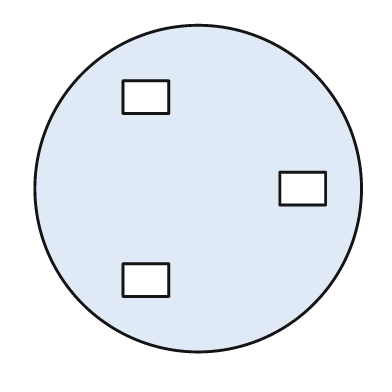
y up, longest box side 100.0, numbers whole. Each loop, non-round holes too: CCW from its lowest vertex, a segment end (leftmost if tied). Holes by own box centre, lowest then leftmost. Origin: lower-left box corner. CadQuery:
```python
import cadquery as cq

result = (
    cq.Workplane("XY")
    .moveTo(50.0, 50.0)
    .circle(50.0)
    .moveTo(27.0, 17.0)
    .lineTo(41.0, 17.0)
    .lineTo(41.0, 27.0)
    .lineTo(27.0, 27.0)
    .close()
    .moveTo(75.0, 45.0)
    .lineTo(89.0, 45.0)
    .lineTo(89.0, 55.0)
    .lineTo(75.0, 55.0)
    .close()
    .moveTo(27.0, 73.0)
    .lineTo(41.0, 73.0)
    .lineTo(41.0, 83.0)
    .lineTo(27.0, 83.0)
    .close()
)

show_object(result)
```